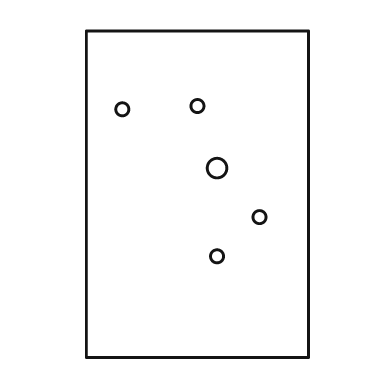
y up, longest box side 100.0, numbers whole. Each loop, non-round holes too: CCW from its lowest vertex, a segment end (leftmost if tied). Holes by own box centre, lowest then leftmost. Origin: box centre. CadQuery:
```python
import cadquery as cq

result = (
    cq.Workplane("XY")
    .moveTo(-34.0, -50.0)
    .lineTo(34.0, -50.0)
    .lineTo(34.0, 50.0)
    .lineTo(-34.0, 50.0)
    .close()
    .moveTo(6.0, -19.0)
    .circle(2.0)
    .moveTo(19.0, -7.0)
    .circle(2.0)
    .moveTo(6.0, 8.0)
    .circle(3.0)
    .moveTo(-23.0, 26.0)
    .circle(2.0)
    .moveTo(0.0, 27.0)
    .circle(2.0)
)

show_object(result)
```